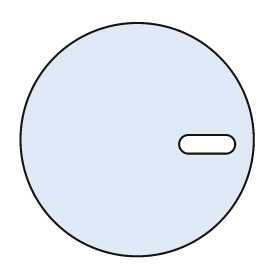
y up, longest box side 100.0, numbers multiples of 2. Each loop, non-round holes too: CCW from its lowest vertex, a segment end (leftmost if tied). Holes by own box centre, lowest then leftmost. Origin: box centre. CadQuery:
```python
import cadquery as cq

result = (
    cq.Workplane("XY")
    .moveTo(0.0, 0.0)
    .circle(50.0)
    .moveTo(22.0, -6.0)
    .lineTo(38.0, -6.0)
    .threePointArc((42.0, -2.0), (38.0, 2.0))
    .lineTo(22.0, 2.0)
    .threePointArc((18.0, -2.0), (22.0, -6.0))
    .close()
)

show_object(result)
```